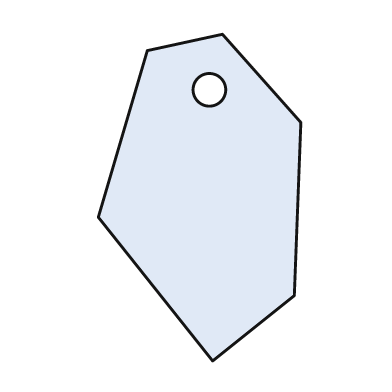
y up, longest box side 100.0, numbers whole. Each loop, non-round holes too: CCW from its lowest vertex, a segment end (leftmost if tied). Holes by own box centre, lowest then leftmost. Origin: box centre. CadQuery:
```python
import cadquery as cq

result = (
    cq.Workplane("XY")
    .moveTo(4.0, -50.0)
    .lineTo(29.0, -30.0)
    .lineTo(31.0, 23.0)
    .lineTo(7.0, 50.0)
    .lineTo(-16.0, 45.0)
    .lineTo(-31.0, -6.0)
    .close()
    .moveTo(3.0, 33.0)
    .circle(5.0)
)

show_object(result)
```